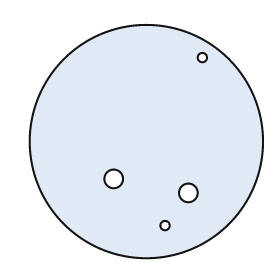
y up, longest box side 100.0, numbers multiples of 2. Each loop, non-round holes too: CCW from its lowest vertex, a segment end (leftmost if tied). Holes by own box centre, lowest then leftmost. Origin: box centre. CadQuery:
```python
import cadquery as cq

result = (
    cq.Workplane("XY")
    .moveTo(0.0, 0.0)
    .circle(50.0)
    .moveTo(8.0, -36.0)
    .circle(2.0)
    .moveTo(18.0, -22.0)
    .circle(4.0)
    .moveTo(-14.0, -16.0)
    .circle(4.0)
    .moveTo(24.0, 36.0)
    .circle(2.0)
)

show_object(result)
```